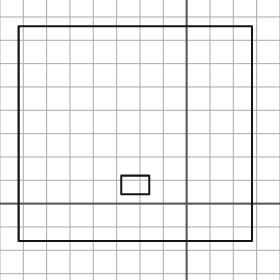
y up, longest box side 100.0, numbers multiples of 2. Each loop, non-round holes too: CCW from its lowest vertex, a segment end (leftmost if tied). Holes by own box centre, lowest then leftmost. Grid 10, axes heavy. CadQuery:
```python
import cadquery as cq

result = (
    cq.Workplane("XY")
    .moveTo(-72.0, -16.0)
    .lineTo(28.0, -16.0)
    .lineTo(28.0, 76.0)
    .lineTo(-72.0, 76.0)
    .close()
    .moveTo(-28.0, 4.0)
    .lineTo(-16.0, 4.0)
    .lineTo(-16.0, 12.0)
    .lineTo(-28.0, 12.0)
    .close()
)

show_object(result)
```